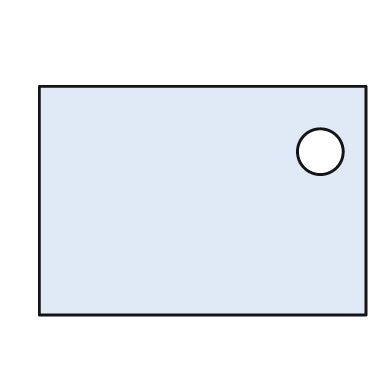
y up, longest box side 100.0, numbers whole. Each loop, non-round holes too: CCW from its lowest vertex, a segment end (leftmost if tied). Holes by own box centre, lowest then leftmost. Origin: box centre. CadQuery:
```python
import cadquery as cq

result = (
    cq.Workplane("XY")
    .moveTo(-50.0, -35.0)
    .lineTo(50.0, -35.0)
    .lineTo(50.0, 35.0)
    .lineTo(-50.0, 35.0)
    .close()
    .moveTo(36.0, 15.0)
    .circle(7.0)
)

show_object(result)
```